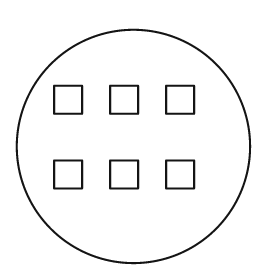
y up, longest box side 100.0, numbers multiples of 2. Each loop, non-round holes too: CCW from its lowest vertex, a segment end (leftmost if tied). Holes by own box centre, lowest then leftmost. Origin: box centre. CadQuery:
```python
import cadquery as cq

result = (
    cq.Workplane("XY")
    .moveTo(0.0, 0.0)
    .circle(50.0)
    .moveTo(-34.0, -18.0)
    .lineTo(-22.0, -18.0)
    .lineTo(-22.0, -6.0)
    .lineTo(-34.0, -6.0)
    .close()
    .moveTo(-10.0, -18.0)
    .lineTo(2.0, -18.0)
    .lineTo(2.0, -6.0)
    .lineTo(-10.0, -6.0)
    .close()
    .moveTo(14.0, -18.0)
    .lineTo(26.0, -18.0)
    .lineTo(26.0, -6.0)
    .lineTo(14.0, -6.0)
    .close()
    .moveTo(-34.0, 14.0)
    .lineTo(-22.0, 14.0)
    .lineTo(-22.0, 26.0)
    .lineTo(-34.0, 26.0)
    .close()
    .moveTo(-10.0, 14.0)
    .lineTo(2.0, 14.0)
    .lineTo(2.0, 26.0)
    .lineTo(-10.0, 26.0)
    .close()
    .moveTo(14.0, 14.0)
    .lineTo(26.0, 14.0)
    .lineTo(26.0, 26.0)
    .lineTo(14.0, 26.0)
    .close()
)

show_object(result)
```